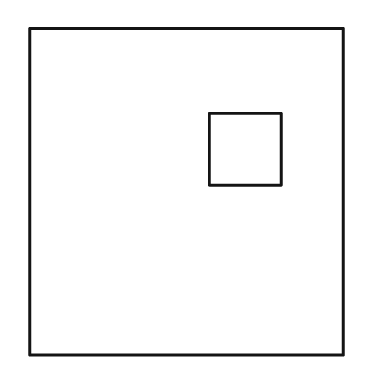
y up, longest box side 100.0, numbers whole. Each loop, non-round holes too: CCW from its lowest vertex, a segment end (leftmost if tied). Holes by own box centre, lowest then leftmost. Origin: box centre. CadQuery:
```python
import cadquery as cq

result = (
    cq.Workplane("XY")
    .moveTo(-48.0, -50.0)
    .lineTo(48.0, -50.0)
    .lineTo(48.0, 50.0)
    .lineTo(-48.0, 50.0)
    .close()
    .moveTo(7.0, 2.0)
    .lineTo(29.0, 2.0)
    .lineTo(29.0, 24.0)
    .lineTo(7.0, 24.0)
    .close()
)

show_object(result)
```